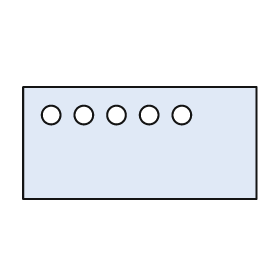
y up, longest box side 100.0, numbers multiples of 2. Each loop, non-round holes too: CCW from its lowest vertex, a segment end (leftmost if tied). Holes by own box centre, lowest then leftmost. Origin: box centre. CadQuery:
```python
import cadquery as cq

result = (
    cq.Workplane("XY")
    .moveTo(-50.0, -24.0)
    .lineTo(50.0, -24.0)
    .lineTo(50.0, 24.0)
    .lineTo(-50.0, 24.0)
    .close()
    .moveTo(-38.0, 12.0)
    .circle(4.0)
    .moveTo(-24.0, 12.0)
    .circle(4.0)
    .moveTo(-10.0, 12.0)
    .circle(4.0)
    .moveTo(4.0, 12.0)
    .circle(4.0)
    .moveTo(18.0, 12.0)
    .circle(4.0)
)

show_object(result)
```